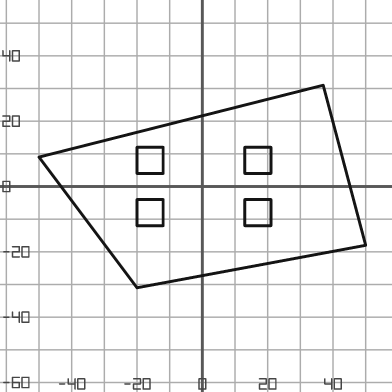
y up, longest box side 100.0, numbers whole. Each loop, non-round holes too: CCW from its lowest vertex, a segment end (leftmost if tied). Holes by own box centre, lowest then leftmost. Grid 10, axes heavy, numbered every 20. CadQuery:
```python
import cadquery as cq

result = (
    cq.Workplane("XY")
    .moveTo(-20.0, -31.0)
    .lineTo(50.0, -18.0)
    .lineTo(37.0, 31.0)
    .lineTo(-50.0, 9.0)
    .close()
    .moveTo(-20.0, -12.0)
    .lineTo(-12.0, -12.0)
    .lineTo(-12.0, -4.0)
    .lineTo(-20.0, -4.0)
    .close()
    .moveTo(13.0, -12.0)
    .lineTo(21.0, -12.0)
    .lineTo(21.0, -4.0)
    .lineTo(13.0, -4.0)
    .close()
    .moveTo(-20.0, 4.0)
    .lineTo(-12.0, 4.0)
    .lineTo(-12.0, 12.0)
    .lineTo(-20.0, 12.0)
    .close()
    .moveTo(13.0, 4.0)
    .lineTo(21.0, 4.0)
    .lineTo(21.0, 12.0)
    .lineTo(13.0, 12.0)
    .close()
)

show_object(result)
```